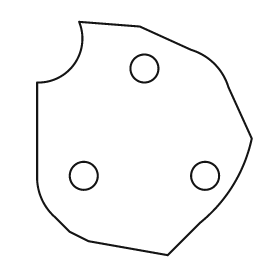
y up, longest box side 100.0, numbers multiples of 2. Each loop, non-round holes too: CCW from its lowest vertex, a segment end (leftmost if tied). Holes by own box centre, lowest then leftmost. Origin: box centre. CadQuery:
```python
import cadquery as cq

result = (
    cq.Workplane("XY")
    .moveTo(10.0, -50.0)
    .lineTo(24.0, -36.0)
    .threePointArc((38.0, -20.0), (46.0, 0.0))
    .lineTo(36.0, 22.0)
    .threePointArc((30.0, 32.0), (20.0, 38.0))
    .lineTo(-2.0, 48.0)
    .lineTo(-28.0, 50.0)
    .threePointArc((-30.0, 32.0), (-46.0, 24.0))
    .lineTo(-46.0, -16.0)
    .threePointArc((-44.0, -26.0), (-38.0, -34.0))
    .lineTo(-32.0, -40.0)
    .lineTo(-24.0, -44.0)
    .close()
    .moveTo(-26.0, -16.0)
    .circle(6.0)
    .moveTo(26.0, -16.0)
    .circle(6.0)
    .moveTo(0.0, 30.0)
    .circle(6.0)
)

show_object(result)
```